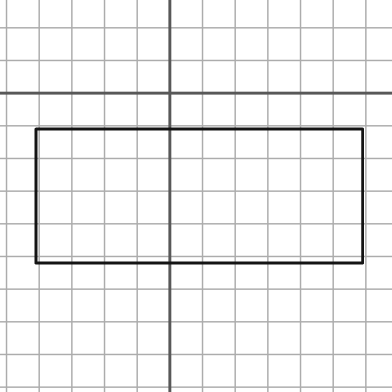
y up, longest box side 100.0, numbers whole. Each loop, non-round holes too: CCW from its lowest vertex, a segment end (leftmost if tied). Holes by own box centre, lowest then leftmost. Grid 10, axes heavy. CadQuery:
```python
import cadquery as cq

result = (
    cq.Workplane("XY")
    .moveTo(-41.0, -52.0)
    .lineTo(59.0, -52.0)
    .lineTo(59.0, -11.0)
    .lineTo(-41.0, -11.0)
    .close()
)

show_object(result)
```